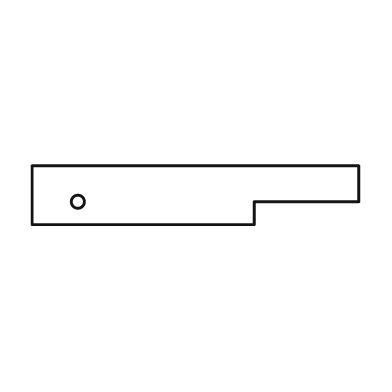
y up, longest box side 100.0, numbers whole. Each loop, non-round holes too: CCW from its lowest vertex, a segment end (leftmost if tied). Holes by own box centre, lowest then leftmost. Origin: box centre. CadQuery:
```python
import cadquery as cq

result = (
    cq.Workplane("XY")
    .moveTo(-50.0, -9.0)
    .lineTo(18.0, -9.0)
    .lineTo(18.0, -2.0)
    .lineTo(50.0, -2.0)
    .lineTo(50.0, 9.0)
    .lineTo(-50.0, 9.0)
    .close()
    .moveTo(-36.0, -2.0)
    .circle(2.0)
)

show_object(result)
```